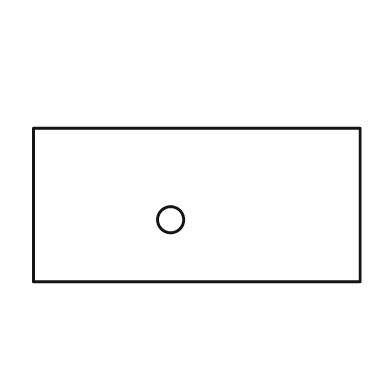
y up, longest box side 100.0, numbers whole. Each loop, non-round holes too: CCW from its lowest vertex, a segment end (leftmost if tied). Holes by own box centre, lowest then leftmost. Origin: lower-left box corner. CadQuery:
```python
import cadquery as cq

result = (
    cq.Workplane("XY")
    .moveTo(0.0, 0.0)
    .lineTo(100.0, 0.0)
    .lineTo(100.0, 47.0)
    .lineTo(0.0, 47.0)
    .close()
    .moveTo(42.0, 19.0)
    .circle(4.0)
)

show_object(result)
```